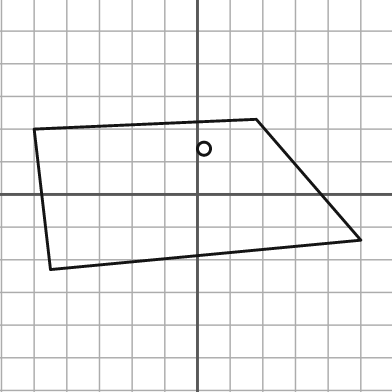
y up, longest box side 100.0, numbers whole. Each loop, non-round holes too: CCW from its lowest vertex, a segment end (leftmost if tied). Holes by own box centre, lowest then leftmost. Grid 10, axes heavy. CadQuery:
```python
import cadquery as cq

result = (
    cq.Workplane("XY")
    .moveTo(-45.0, -23.0)
    .lineTo(50.0, -14.0)
    .lineTo(18.0, 23.0)
    .lineTo(-50.0, 20.0)
    .close()
    .moveTo(2.0, 14.0)
    .circle(2.0)
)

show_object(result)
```